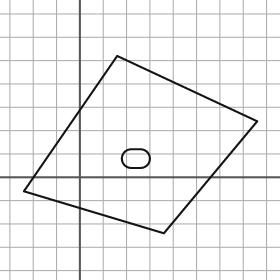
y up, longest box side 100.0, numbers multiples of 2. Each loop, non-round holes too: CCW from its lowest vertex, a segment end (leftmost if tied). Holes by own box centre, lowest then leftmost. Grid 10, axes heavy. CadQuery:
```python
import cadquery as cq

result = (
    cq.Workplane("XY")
    .moveTo(36.0, -24.0)
    .lineTo(76.0, 24.0)
    .lineTo(16.0, 52.0)
    .lineTo(-24.0, -6.0)
    .close()
    .moveTo(22.0, 4.0)
    .lineTo(26.0, 4.0)
    .threePointArc((30.0, 8.0), (26.0, 12.0))
    .lineTo(22.0, 12.0)
    .threePointArc((18.0, 8.0), (22.0, 4.0))
    .close()
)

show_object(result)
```